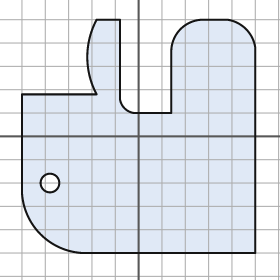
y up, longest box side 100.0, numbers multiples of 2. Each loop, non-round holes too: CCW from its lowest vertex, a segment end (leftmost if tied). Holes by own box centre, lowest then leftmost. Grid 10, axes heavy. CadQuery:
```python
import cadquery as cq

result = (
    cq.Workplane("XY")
    .moveTo(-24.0, -50.0)
    .lineTo(50.0, -50.0)
    .lineTo(50.0, 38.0)
    .threePointArc((46.0, 46.0), (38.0, 50.0))
    .lineTo(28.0, 50.0)
    .threePointArc((18.0, 46.0), (14.0, 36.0))
    .lineTo(14.0, 10.0)
    .lineTo(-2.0, 10.0)
    .threePointArc((-6.0, 12.0), (-8.0, 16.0))
    .lineTo(-8.0, 50.0)
    .lineTo(-18.0, 50.0)
    .threePointArc((-22.0, 34.0), (-18.0, 18.0))
    .lineTo(-50.0, 18.0)
    .lineTo(-50.0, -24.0)
    .threePointArc((-42.0, -42.0), (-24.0, -50.0))
    .close()
    .moveTo(-38.0, -20.0)
    .circle(4.0)
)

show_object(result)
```